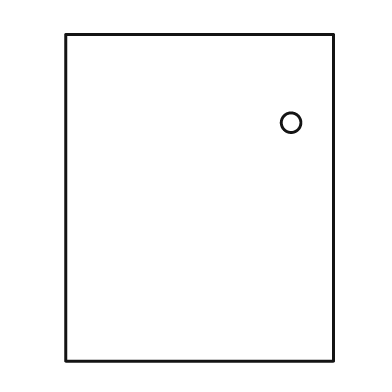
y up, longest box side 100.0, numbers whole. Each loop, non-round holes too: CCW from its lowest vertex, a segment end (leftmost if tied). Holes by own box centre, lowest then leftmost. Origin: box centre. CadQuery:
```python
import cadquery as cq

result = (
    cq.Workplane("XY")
    .moveTo(-41.0, -50.0)
    .lineTo(41.0, -50.0)
    .lineTo(41.0, 50.0)
    .lineTo(-41.0, 50.0)
    .close()
    .moveTo(28.0, 23.0)
    .circle(3.0)
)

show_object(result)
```